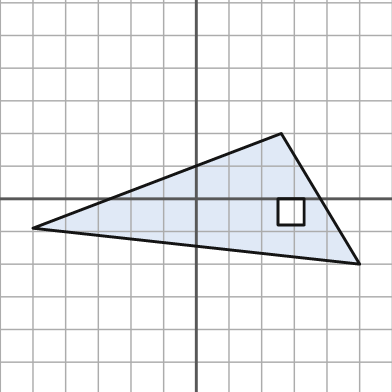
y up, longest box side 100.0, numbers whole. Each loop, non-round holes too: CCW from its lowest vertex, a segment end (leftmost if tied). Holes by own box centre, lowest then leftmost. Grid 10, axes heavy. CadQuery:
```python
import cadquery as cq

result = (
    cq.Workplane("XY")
    .moveTo(50.0, -20.0)
    .lineTo(26.0, 20.0)
    .lineTo(-50.0, -9.0)
    .close()
    .moveTo(25.0, -8.0)
    .lineTo(33.0, -8.0)
    .lineTo(33.0, 0.0)
    .lineTo(25.0, 0.0)
    .close()
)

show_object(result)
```